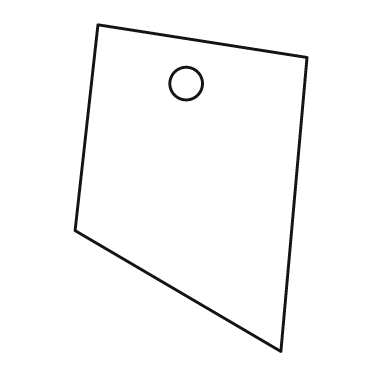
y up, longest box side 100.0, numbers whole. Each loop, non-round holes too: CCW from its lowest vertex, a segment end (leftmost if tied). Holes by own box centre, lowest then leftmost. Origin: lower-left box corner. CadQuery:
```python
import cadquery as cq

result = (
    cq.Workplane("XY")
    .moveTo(63.0, 0.0)
    .lineTo(71.0, 90.0)
    .lineTo(7.0, 100.0)
    .lineTo(0.0, 37.0)
    .close()
    .moveTo(34.0, 82.0)
    .circle(5.0)
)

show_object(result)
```